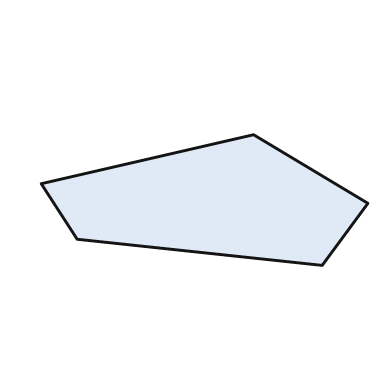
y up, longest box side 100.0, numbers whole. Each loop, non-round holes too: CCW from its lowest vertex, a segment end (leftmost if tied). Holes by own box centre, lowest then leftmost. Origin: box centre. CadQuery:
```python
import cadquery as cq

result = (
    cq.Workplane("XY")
    .moveTo(36.0, -20.0)
    .lineTo(50.0, -1.0)
    .lineTo(15.0, 20.0)
    .lineTo(-50.0, 5.0)
    .lineTo(-39.0, -12.0)
    .close()
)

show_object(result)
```